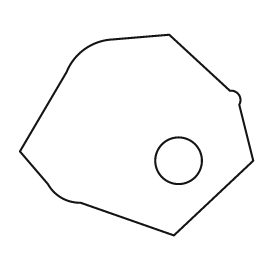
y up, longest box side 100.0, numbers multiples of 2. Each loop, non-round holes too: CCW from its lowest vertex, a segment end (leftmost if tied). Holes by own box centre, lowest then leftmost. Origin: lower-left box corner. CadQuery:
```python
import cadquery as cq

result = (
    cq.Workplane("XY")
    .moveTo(66.0, 0.0)
    .lineTo(100.0, 32.0)
    .lineTo(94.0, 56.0)
    .threePointArc((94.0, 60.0), (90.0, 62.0))
    .lineTo(64.0, 86.0)
    .lineTo(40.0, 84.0)
    .threePointArc((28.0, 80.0), (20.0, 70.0))
    .lineTo(0.0, 36.0)
    .lineTo(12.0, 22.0)
    .threePointArc((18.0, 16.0), (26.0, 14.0))
    .close()
    .moveTo(68.0, 32.0)
    .circle(10.0)
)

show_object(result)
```